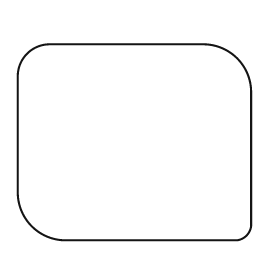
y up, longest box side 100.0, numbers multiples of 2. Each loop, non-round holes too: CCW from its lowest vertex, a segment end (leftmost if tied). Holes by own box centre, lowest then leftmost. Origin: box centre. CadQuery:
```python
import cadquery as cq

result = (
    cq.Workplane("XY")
    .moveTo(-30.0, -42.0)
    .lineTo(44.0, -42.0)
    .threePointArc((48.0, -40.0), (50.0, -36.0))
    .lineTo(50.0, 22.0)
    .threePointArc((44.0, 36.0), (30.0, 42.0))
    .lineTo(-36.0, 42.0)
    .threePointArc((-46.0, 38.0), (-50.0, 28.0))
    .lineTo(-50.0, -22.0)
    .threePointArc((-44.0, -36.0), (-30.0, -42.0))
    .close()
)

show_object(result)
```